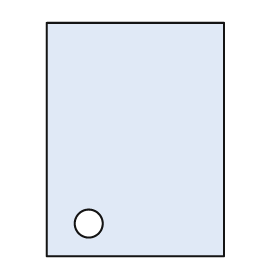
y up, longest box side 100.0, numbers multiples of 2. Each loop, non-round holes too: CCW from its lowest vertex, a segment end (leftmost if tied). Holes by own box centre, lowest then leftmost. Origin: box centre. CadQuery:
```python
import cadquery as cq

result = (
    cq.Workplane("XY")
    .moveTo(-38.0, -50.0)
    .lineTo(38.0, -50.0)
    .lineTo(38.0, 50.0)
    .lineTo(-38.0, 50.0)
    .close()
    .moveTo(-20.0, -36.0)
    .circle(6.0)
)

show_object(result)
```